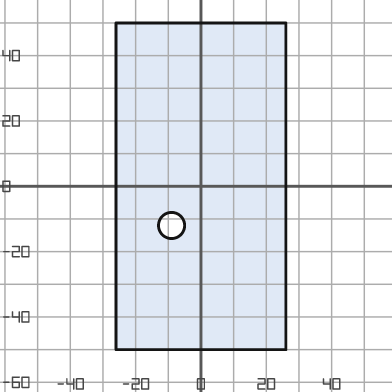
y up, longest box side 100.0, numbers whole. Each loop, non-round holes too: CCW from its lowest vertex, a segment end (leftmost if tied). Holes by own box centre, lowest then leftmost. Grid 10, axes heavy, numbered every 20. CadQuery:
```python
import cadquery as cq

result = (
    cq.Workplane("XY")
    .moveTo(-26.0, -50.0)
    .lineTo(26.0, -50.0)
    .lineTo(26.0, 50.0)
    .lineTo(-26.0, 50.0)
    .close()
    .moveTo(-9.0, -12.0)
    .circle(4.0)
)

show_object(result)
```